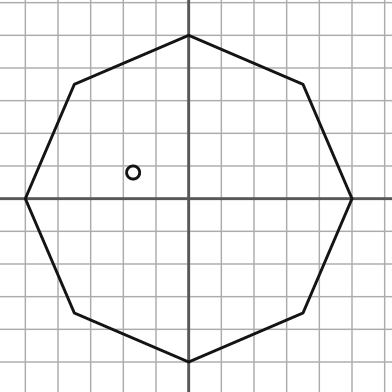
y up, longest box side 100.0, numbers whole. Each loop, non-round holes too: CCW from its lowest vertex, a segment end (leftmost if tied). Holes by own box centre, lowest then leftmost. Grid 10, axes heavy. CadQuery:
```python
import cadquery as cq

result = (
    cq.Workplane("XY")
    .moveTo(0.0, -50.0)
    .lineTo(35.0, -35.0)
    .lineTo(50.0, 0.0)
    .lineTo(35.0, 35.0)
    .lineTo(0.0, 50.0)
    .lineTo(-35.0, 35.0)
    .lineTo(-50.0, 0.0)
    .lineTo(-35.0, -35.0)
    .close()
    .moveTo(-17.0, 8.0)
    .circle(2.0)
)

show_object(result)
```